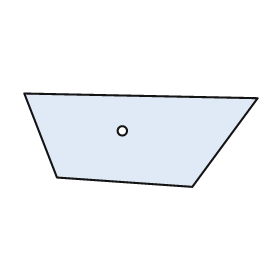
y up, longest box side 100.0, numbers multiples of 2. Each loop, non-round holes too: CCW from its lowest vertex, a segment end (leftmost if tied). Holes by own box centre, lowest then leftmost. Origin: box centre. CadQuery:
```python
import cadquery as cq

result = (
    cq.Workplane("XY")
    .moveTo(22.0, -20.0)
    .lineTo(50.0, 18.0)
    .lineTo(-50.0, 20.0)
    .lineTo(-36.0, -16.0)
    .close()
    .moveTo(-8.0, 4.0)
    .circle(2.0)
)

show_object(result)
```